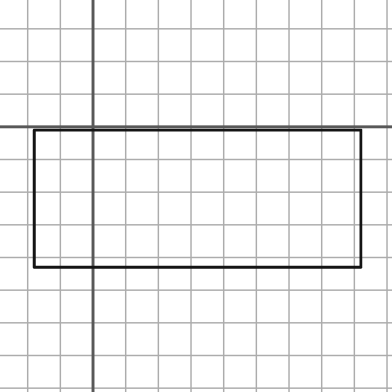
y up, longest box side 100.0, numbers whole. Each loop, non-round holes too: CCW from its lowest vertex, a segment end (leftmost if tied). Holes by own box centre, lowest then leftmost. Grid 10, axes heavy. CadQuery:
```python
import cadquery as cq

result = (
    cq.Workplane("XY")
    .moveTo(-18.0, -43.0)
    .lineTo(82.0, -43.0)
    .lineTo(82.0, -1.0)
    .lineTo(-18.0, -1.0)
    .close()
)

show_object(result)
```